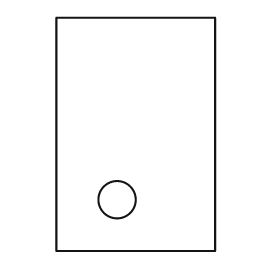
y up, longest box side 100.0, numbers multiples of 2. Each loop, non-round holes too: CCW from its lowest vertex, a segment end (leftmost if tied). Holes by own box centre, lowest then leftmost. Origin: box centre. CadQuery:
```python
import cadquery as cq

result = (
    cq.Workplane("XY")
    .moveTo(-34.0, -50.0)
    .lineTo(34.0, -50.0)
    .lineTo(34.0, 50.0)
    .lineTo(-34.0, 50.0)
    .close()
    .moveTo(-8.0, -28.0)
    .circle(8.0)
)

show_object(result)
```